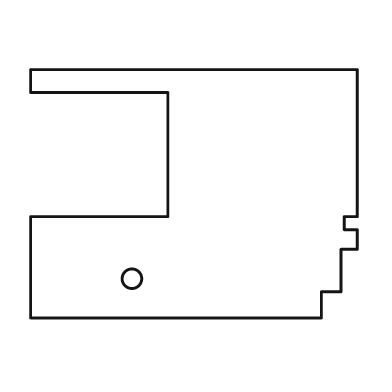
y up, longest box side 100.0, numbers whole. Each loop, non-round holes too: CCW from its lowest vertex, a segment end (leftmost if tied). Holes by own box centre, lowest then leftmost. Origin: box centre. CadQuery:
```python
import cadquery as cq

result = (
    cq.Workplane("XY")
    .moveTo(-50.0, -38.0)
    .lineTo(39.0, -38.0)
    .lineTo(39.0, -30.0)
    .lineTo(45.0, -30.0)
    .lineTo(45.0, -17.0)
    .lineTo(50.0, -17.0)
    .lineTo(50.0, -11.0)
    .lineTo(46.0, -11.0)
    .lineTo(46.0, -7.0)
    .lineTo(50.0, -7.0)
    .lineTo(50.0, 38.0)
    .lineTo(-50.0, 38.0)
    .lineTo(-50.0, 31.0)
    .lineTo(-8.0, 31.0)
    .lineTo(-8.0, -7.0)
    .lineTo(-50.0, -7.0)
    .close()
    .moveTo(-19.0, -26.0)
    .circle(3.0)
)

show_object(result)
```